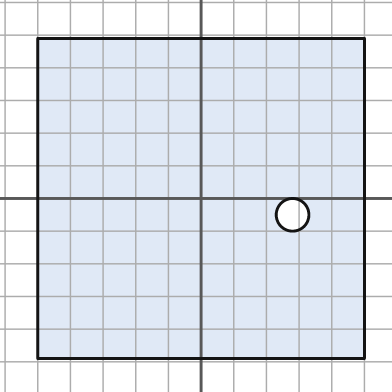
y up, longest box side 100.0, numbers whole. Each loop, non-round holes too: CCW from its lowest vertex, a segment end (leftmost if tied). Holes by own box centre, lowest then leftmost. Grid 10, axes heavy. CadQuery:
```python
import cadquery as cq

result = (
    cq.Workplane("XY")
    .moveTo(-50.0, -49.0)
    .lineTo(50.0, -49.0)
    .lineTo(50.0, 49.0)
    .lineTo(-50.0, 49.0)
    .close()
    .moveTo(28.0, -5.0)
    .circle(5.0)
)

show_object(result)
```